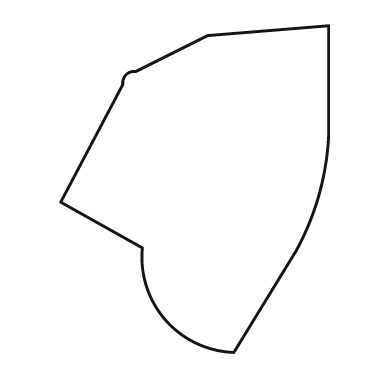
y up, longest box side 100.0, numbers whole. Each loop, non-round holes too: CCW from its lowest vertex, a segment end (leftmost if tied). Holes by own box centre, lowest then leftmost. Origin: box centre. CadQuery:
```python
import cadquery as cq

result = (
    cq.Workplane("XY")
    .moveTo(12.0, -50.0)
    .lineTo(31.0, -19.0)
    .threePointArc((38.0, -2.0), (41.0, 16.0))
    .lineTo(41.0, 50.0)
    .lineTo(4.0, 47.0)
    .lineTo(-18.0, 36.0)
    .threePointArc((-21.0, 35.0), (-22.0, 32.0))
    .lineTo(-41.0, -4.0)
    .lineTo(-16.0, -18.0)
    .threePointArc((-9.0, -40.0), (12.0, -50.0))
    .close()
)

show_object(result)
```